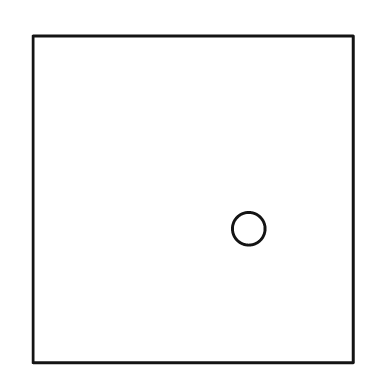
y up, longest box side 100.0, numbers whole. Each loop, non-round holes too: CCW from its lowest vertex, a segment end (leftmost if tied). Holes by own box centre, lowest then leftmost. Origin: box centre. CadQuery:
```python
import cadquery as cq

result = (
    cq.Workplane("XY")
    .moveTo(-49.0, -50.0)
    .lineTo(49.0, -50.0)
    .lineTo(49.0, 50.0)
    .lineTo(-49.0, 50.0)
    .close()
    .moveTo(17.0, -9.0)
    .circle(5.0)
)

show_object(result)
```